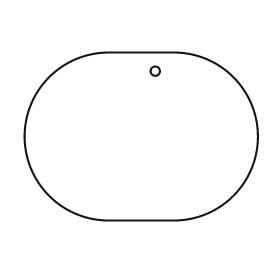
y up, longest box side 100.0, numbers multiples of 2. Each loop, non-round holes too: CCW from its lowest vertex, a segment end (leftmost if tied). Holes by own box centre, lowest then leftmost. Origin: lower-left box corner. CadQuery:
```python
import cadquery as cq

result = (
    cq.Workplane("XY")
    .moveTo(36.0, 0.0)
    .lineTo(64.0, 0.0)
    .threePointArc((100.0, 36.0), (64.0, 72.0))
    .lineTo(36.0, 72.0)
    .threePointArc((0.0, 36.0), (36.0, 0.0))
    .close()
    .moveTo(56.0, 64.0)
    .circle(2.0)
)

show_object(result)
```